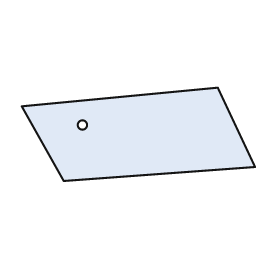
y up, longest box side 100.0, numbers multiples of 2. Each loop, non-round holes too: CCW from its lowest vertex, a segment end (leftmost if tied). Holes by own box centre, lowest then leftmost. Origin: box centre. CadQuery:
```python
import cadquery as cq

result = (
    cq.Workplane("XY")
    .moveTo(-32.0, -20.0)
    .lineTo(50.0, -14.0)
    .lineTo(34.0, 20.0)
    .lineTo(-50.0, 12.0)
    .close()
    .moveTo(-24.0, 4.0)
    .circle(2.0)
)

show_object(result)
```